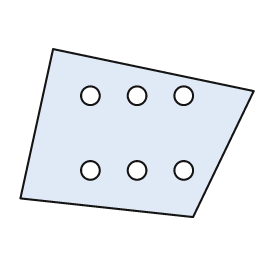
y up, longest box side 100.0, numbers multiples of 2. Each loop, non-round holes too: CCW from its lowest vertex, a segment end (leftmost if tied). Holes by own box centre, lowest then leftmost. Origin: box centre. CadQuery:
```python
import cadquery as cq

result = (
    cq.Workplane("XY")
    .moveTo(24.0, -36.0)
    .lineTo(50.0, 18.0)
    .lineTo(-36.0, 36.0)
    .lineTo(-50.0, -28.0)
    .close()
    .moveTo(-20.0, -16.0)
    .circle(4.0)
    .moveTo(0.0, -16.0)
    .circle(4.0)
    .moveTo(20.0, -16.0)
    .circle(4.0)
    .moveTo(-20.0, 16.0)
    .circle(4.0)
    .moveTo(0.0, 16.0)
    .circle(4.0)
    .moveTo(20.0, 16.0)
    .circle(4.0)
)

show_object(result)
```